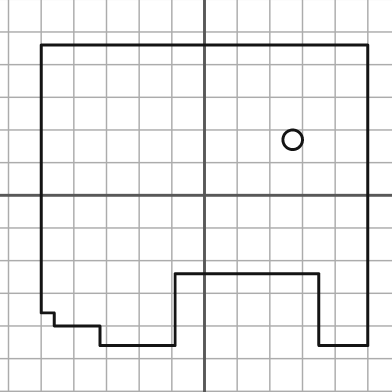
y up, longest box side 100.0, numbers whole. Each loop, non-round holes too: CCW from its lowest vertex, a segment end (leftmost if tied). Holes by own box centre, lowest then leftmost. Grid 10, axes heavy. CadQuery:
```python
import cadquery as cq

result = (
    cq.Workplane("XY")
    .moveTo(-32.0, -46.0)
    .lineTo(-9.0, -46.0)
    .lineTo(-9.0, -24.0)
    .lineTo(35.0, -24.0)
    .lineTo(35.0, -46.0)
    .lineTo(50.0, -46.0)
    .lineTo(50.0, 46.0)
    .lineTo(-50.0, 46.0)
    .lineTo(-50.0, -36.0)
    .lineTo(-46.0, -36.0)
    .lineTo(-46.0, -40.0)
    .lineTo(-32.0, -40.0)
    .close()
    .moveTo(27.0, 17.0)
    .circle(3.0)
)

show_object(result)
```